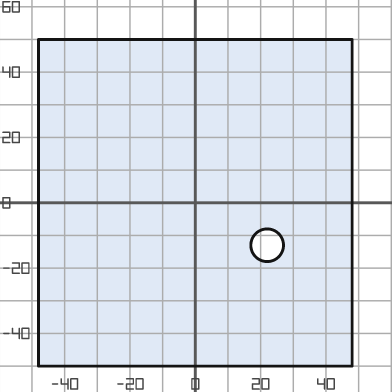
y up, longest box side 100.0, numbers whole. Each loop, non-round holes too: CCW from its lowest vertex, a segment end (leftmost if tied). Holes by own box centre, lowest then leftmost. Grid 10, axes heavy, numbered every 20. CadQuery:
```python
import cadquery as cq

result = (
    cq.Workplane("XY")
    .moveTo(-48.0, -50.0)
    .lineTo(48.0, -50.0)
    .lineTo(48.0, 50.0)
    .lineTo(-48.0, 50.0)
    .close()
    .moveTo(22.0, -13.0)
    .circle(5.0)
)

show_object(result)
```